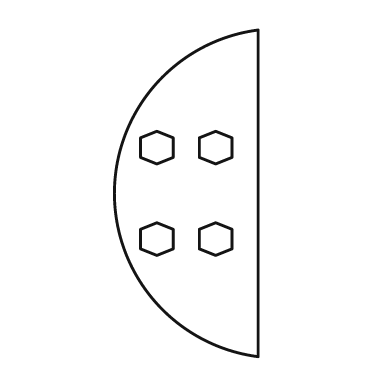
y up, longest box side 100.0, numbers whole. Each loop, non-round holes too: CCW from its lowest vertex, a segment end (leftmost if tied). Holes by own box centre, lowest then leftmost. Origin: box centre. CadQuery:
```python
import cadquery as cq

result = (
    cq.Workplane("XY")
    .moveTo(22.0, -50.0)
    .lineTo(22.0, 50.0)
    .threePointArc((-22.0, 0.0), (22.0, -50.0))
    .close()
    .moveTo(-9.0, -19.0)
    .lineTo(-4.0, -17.0)
    .lineTo(-4.0, -11.0)
    .lineTo(-9.0, -9.0)
    .lineTo(-14.0, -11.0)
    .lineTo(-14.0, -17.0)
    .close()
    .moveTo(9.0, -19.0)
    .lineTo(14.0, -17.0)
    .lineTo(14.0, -11.0)
    .lineTo(9.0, -9.0)
    .lineTo(4.0, -11.0)
    .lineTo(4.0, -17.0)
    .close()
    .moveTo(-9.0, 9.0)
    .lineTo(-4.0, 11.0)
    .lineTo(-4.0, 17.0)
    .lineTo(-9.0, 19.0)
    .lineTo(-14.0, 17.0)
    .lineTo(-14.0, 11.0)
    .close()
    .moveTo(9.0, 9.0)
    .lineTo(14.0, 11.0)
    .lineTo(14.0, 17.0)
    .lineTo(9.0, 19.0)
    .lineTo(4.0, 17.0)
    .lineTo(4.0, 11.0)
    .close()
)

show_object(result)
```